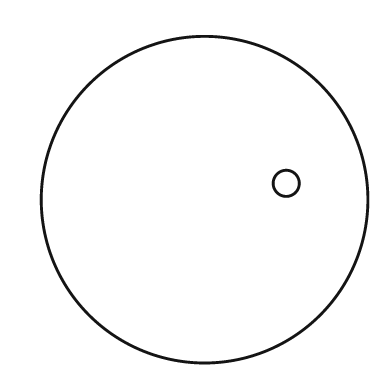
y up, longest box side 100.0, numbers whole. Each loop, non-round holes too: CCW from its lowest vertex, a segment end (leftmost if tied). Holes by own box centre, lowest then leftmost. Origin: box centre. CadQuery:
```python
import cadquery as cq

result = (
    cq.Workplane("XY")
    .moveTo(0.0, 0.0)
    .circle(50.0)
    .moveTo(25.0, 5.0)
    .circle(4.0)
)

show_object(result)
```